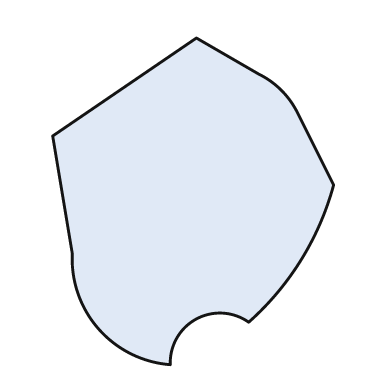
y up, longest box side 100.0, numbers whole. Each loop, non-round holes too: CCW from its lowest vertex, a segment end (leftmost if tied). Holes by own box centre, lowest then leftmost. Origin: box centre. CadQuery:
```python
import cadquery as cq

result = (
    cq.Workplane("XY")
    .moveTo(-7.0, -50.0)
    .threePointArc((1.0, -36.0), (17.0, -37.0))
    .threePointArc((33.0, -18.0), (43.0, 5.0))
    .lineTo(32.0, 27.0)
    .threePointArc((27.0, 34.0), (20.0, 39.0))
    .lineTo(1.0, 50.0)
    .lineTo(-43.0, 20.0)
    .lineTo(-37.0, -16.0)
    .threePointArc((-29.0, -39.0), (-7.0, -50.0))
    .close()
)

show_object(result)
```